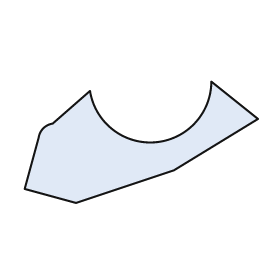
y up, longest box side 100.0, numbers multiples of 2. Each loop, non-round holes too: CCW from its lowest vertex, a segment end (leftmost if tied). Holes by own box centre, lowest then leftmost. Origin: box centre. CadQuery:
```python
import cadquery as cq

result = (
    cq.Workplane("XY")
    .moveTo(-28.0, -26.0)
    .lineTo(14.0, -12.0)
    .lineTo(50.0, 10.0)
    .lineTo(30.0, 26.0)
    .threePointArc((6.0, 0.0), (-22.0, 22.0))
    .lineTo(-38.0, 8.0)
    .threePointArc((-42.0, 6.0), (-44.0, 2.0))
    .lineTo(-50.0, -20.0)
    .close()
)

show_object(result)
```